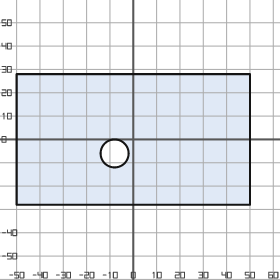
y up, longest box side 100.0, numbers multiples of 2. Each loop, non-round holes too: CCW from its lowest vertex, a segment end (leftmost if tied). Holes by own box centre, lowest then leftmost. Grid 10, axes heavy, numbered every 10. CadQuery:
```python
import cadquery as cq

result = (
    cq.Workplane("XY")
    .moveTo(-50.0, -28.0)
    .lineTo(50.0, -28.0)
    .lineTo(50.0, 28.0)
    .lineTo(-50.0, 28.0)
    .close()
    .moveTo(-8.0, -6.0)
    .circle(6.0)
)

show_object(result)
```